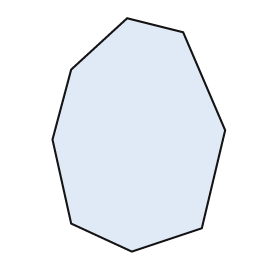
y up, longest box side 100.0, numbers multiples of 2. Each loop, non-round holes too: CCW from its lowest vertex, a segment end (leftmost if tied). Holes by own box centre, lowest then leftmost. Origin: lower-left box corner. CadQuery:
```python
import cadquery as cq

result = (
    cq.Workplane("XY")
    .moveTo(34.0, 0.0)
    .lineTo(64.0, 10.0)
    .lineTo(74.0, 52.0)
    .lineTo(56.0, 94.0)
    .lineTo(32.0, 100.0)
    .lineTo(8.0, 78.0)
    .lineTo(0.0, 48.0)
    .lineTo(8.0, 12.0)
    .close()
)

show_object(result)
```